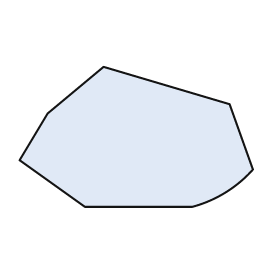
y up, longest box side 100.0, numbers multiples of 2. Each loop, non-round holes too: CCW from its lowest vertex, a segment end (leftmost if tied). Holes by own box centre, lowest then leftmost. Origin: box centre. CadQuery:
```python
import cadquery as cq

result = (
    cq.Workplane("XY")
    .moveTo(-22.0, -30.0)
    .lineTo(24.0, -30.0)
    .threePointArc((38.0, -24.0), (50.0, -14.0))
    .lineTo(40.0, 14.0)
    .lineTo(-14.0, 30.0)
    .lineTo(-38.0, 10.0)
    .lineTo(-50.0, -10.0)
    .close()
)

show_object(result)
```